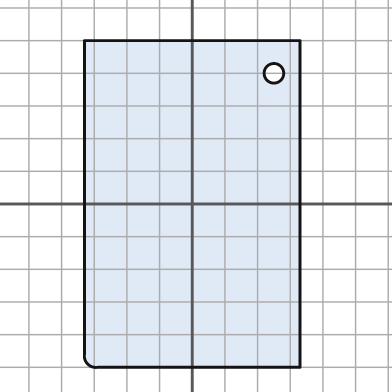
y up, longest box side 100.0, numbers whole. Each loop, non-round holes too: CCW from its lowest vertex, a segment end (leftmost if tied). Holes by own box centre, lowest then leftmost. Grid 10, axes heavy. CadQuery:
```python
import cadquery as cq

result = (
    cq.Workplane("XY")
    .moveTo(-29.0, -50.0)
    .lineTo(33.0, -50.0)
    .lineTo(33.0, 50.0)
    .lineTo(-33.0, 50.0)
    .lineTo(-33.0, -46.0)
    .threePointArc((-32.0, -49.0), (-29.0, -50.0))
    .close()
    .moveTo(25.0, 40.0)
    .circle(3.0)
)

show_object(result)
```